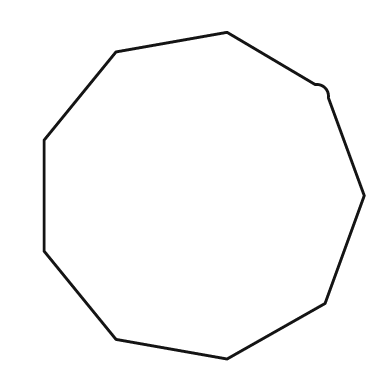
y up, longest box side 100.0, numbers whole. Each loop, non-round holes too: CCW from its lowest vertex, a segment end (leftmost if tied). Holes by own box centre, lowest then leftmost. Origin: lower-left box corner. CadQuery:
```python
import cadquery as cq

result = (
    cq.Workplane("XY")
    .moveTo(56.0, 0.0)
    .lineTo(86.0, 17.0)
    .lineTo(98.0, 50.0)
    .lineTo(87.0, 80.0)
    .threePointArc((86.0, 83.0), (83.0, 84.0))
    .lineTo(56.0, 100.0)
    .lineTo(22.0, 94.0)
    .lineTo(0.0, 67.0)
    .lineTo(0.0, 33.0)
    .lineTo(22.0, 6.0)
    .close()
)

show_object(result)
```